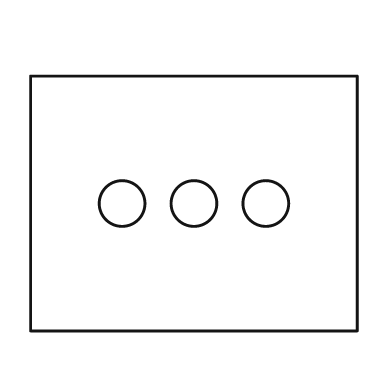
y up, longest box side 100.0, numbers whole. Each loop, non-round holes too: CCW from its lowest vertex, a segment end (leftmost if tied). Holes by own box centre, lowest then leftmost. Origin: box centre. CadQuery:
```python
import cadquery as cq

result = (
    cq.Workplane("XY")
    .moveTo(-50.0, -39.0)
    .lineTo(50.0, -39.0)
    .lineTo(50.0, 39.0)
    .lineTo(-50.0, 39.0)
    .close()
    .moveTo(-22.0, 0.0)
    .circle(7.0)
    .moveTo(0.0, 0.0)
    .circle(7.0)
    .moveTo(22.0, 0.0)
    .circle(7.0)
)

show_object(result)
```